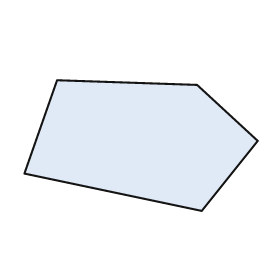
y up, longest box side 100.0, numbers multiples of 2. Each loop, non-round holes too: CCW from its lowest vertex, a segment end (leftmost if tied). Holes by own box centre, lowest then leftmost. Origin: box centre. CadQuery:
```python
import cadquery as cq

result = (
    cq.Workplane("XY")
    .moveTo(26.0, -28.0)
    .lineTo(50.0, 2.0)
    .lineTo(24.0, 26.0)
    .lineTo(-36.0, 28.0)
    .lineTo(-50.0, -12.0)
    .close()
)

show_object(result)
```